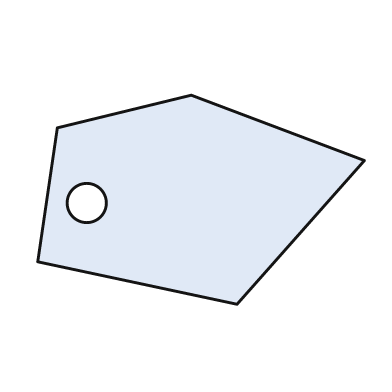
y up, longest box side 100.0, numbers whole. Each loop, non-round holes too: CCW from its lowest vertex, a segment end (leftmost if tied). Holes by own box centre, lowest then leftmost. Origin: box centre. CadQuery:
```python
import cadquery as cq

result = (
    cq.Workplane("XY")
    .moveTo(11.0, -32.0)
    .lineTo(50.0, 12.0)
    .lineTo(-3.0, 32.0)
    .lineTo(-44.0, 22.0)
    .lineTo(-50.0, -19.0)
    .close()
    .moveTo(-35.0, -1.0)
    .circle(6.0)
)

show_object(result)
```